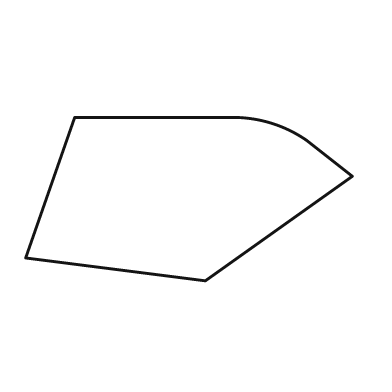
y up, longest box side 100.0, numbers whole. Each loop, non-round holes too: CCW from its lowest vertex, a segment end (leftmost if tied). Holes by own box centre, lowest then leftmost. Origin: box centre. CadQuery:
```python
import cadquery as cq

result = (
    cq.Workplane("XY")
    .moveTo(5.0, -25.0)
    .lineTo(50.0, 7.0)
    .lineTo(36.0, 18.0)
    .threePointArc((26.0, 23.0), (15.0, 25.0))
    .lineTo(-35.0, 25.0)
    .lineTo(-50.0, -18.0)
    .close()
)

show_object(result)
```